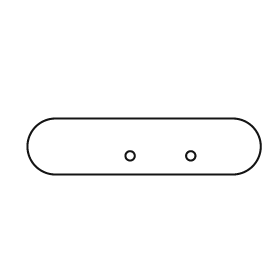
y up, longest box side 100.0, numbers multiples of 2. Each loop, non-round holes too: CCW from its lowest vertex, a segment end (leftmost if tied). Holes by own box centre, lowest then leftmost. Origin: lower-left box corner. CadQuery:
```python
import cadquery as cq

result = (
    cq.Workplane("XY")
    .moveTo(12.0, 0.0)
    .lineTo(88.0, 0.0)
    .threePointArc((100.0, 12.0), (88.0, 24.0))
    .lineTo(12.0, 24.0)
    .threePointArc((0.0, 12.0), (12.0, 0.0))
    .close()
    .moveTo(44.0, 8.0)
    .circle(2.0)
    .moveTo(70.0, 8.0)
    .circle(2.0)
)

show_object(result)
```